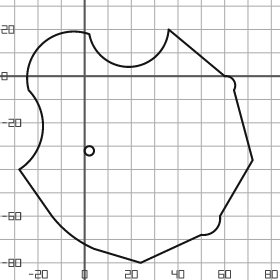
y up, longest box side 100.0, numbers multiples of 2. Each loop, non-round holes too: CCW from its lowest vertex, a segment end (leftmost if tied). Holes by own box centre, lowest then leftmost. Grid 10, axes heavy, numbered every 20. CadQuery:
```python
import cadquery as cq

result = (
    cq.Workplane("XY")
    .moveTo(24.0, -80.0)
    .lineTo(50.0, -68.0)
    .threePointArc((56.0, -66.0), (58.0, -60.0))
    .lineTo(72.0, -36.0)
    .lineTo(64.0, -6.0)
    .threePointArc((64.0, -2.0), (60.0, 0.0))
    .lineTo(36.0, 20.0)
    .threePointArc((20.0, 4.0), (2.0, 18.0))
    .threePointArc((-18.0, 14.0), (-24.0, -6.0))
    .threePointArc((-18.0, -24.0), (-28.0, -40.0))
    .lineTo(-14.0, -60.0)
    .threePointArc((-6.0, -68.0), (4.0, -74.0))
    .close()
    .moveTo(2.0, -32.0)
    .circle(2.0)
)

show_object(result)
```